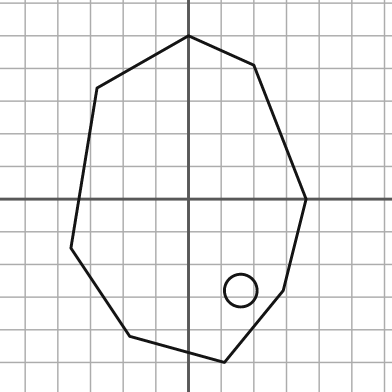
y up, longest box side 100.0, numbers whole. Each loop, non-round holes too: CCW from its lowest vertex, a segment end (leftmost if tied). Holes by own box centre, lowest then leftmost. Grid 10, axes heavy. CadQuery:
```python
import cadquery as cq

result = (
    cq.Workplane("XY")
    .moveTo(11.0, -50.0)
    .lineTo(29.0, -28.0)
    .lineTo(36.0, 0.0)
    .lineTo(20.0, 41.0)
    .lineTo(0.0, 50.0)
    .lineTo(-28.0, 34.0)
    .lineTo(-36.0, -15.0)
    .lineTo(-18.0, -42.0)
    .close()
    .moveTo(16.0, -28.0)
    .circle(5.0)
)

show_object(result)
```